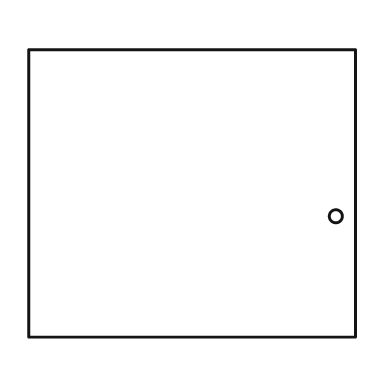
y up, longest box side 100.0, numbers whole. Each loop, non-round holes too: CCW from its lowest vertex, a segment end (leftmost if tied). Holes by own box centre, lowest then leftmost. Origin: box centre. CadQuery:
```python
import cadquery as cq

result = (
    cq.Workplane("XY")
    .moveTo(-50.0, -44.0)
    .lineTo(50.0, -44.0)
    .lineTo(50.0, 44.0)
    .lineTo(-50.0, 44.0)
    .close()
    .moveTo(44.0, -7.0)
    .circle(2.0)
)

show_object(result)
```